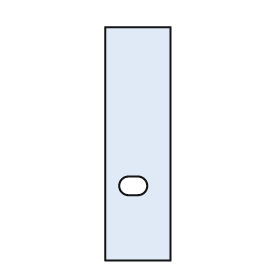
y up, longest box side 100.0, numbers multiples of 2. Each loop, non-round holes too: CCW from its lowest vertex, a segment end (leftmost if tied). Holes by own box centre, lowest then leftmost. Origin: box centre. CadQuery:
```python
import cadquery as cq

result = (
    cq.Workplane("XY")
    .moveTo(-14.0, -50.0)
    .lineTo(14.0, -50.0)
    .lineTo(14.0, 50.0)
    .lineTo(-14.0, 50.0)
    .close()
    .moveTo(-4.0, -22.0)
    .lineTo(0.0, -22.0)
    .threePointArc((4.0, -18.0), (0.0, -14.0))
    .lineTo(-4.0, -14.0)
    .threePointArc((-8.0, -18.0), (-4.0, -22.0))
    .close()
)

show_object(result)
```